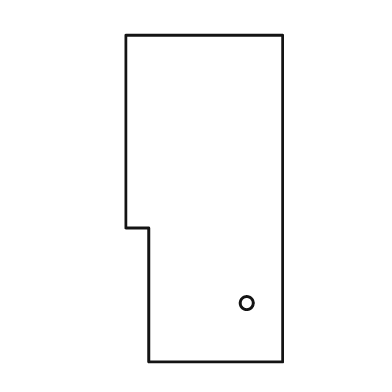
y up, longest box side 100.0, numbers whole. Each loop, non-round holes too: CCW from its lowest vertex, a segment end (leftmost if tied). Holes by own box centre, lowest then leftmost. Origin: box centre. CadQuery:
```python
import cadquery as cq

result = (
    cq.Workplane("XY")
    .moveTo(-17.0, -50.0)
    .lineTo(24.0, -50.0)
    .lineTo(24.0, 50.0)
    .lineTo(-24.0, 50.0)
    .lineTo(-24.0, -9.0)
    .lineTo(-17.0, -9.0)
    .close()
    .moveTo(13.0, -32.0)
    .circle(2.0)
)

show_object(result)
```